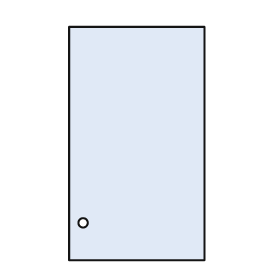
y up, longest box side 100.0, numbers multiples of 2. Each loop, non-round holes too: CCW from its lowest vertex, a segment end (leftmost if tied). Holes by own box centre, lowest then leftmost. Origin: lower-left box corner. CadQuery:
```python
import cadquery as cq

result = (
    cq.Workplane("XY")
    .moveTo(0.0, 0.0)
    .lineTo(58.0, 0.0)
    .lineTo(58.0, 100.0)
    .lineTo(0.0, 100.0)
    .close()
    .moveTo(6.0, 16.0)
    .circle(2.0)
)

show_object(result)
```